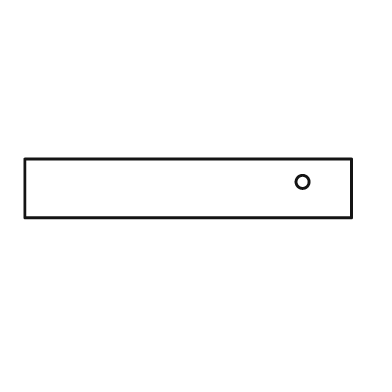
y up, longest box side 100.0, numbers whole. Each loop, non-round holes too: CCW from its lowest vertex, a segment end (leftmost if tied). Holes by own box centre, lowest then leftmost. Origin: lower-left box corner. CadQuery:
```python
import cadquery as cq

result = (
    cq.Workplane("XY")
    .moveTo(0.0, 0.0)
    .lineTo(100.0, 0.0)
    .lineTo(100.0, 18.0)
    .lineTo(0.0, 18.0)
    .close()
    .moveTo(85.0, 11.0)
    .circle(2.0)
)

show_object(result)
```